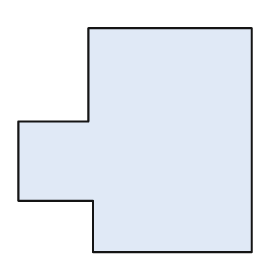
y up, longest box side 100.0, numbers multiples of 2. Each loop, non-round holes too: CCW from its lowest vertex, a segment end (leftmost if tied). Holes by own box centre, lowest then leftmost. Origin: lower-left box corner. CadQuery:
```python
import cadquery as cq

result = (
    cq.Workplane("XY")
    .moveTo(32.0, 0.0)
    .lineTo(100.0, 0.0)
    .lineTo(100.0, 96.0)
    .lineTo(30.0, 96.0)
    .lineTo(30.0, 56.0)
    .lineTo(0.0, 56.0)
    .lineTo(0.0, 22.0)
    .lineTo(32.0, 22.0)
    .close()
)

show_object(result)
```